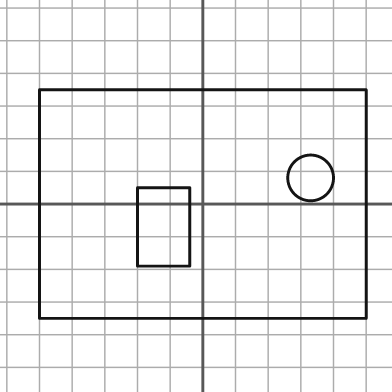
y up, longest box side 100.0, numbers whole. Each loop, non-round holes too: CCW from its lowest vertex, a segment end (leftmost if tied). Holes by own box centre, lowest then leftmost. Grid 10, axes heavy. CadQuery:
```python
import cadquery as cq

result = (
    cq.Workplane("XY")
    .moveTo(-50.0, -35.0)
    .lineTo(50.0, -35.0)
    .lineTo(50.0, 35.0)
    .lineTo(-50.0, 35.0)
    .close()
    .moveTo(-20.0, -19.0)
    .lineTo(-4.0, -19.0)
    .lineTo(-4.0, 5.0)
    .lineTo(-20.0, 5.0)
    .close()
    .moveTo(33.0, 8.0)
    .circle(7.0)
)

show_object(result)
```